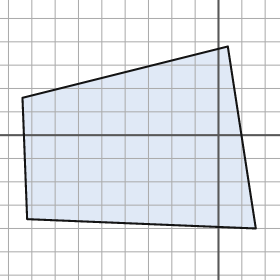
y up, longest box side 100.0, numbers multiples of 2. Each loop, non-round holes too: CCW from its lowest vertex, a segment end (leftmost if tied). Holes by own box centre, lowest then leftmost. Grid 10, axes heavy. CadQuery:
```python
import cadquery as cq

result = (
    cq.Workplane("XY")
    .moveTo(16.0, -40.0)
    .lineTo(4.0, 38.0)
    .lineTo(-84.0, 16.0)
    .lineTo(-82.0, -36.0)
    .close()
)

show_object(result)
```